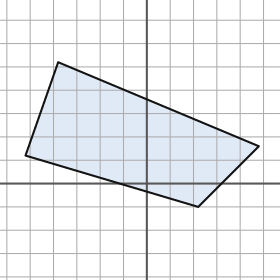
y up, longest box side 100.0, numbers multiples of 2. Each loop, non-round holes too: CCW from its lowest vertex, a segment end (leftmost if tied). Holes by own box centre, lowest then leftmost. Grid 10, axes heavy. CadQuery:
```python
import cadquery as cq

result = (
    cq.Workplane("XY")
    .moveTo(22.0, -10.0)
    .lineTo(48.0, 16.0)
    .lineTo(-38.0, 52.0)
    .lineTo(-52.0, 12.0)
    .close()
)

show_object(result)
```